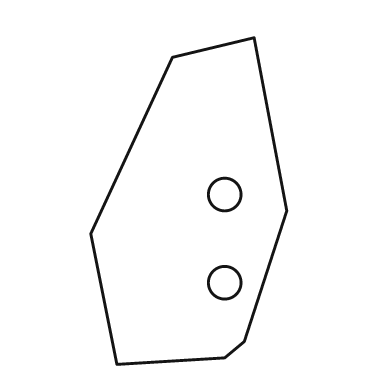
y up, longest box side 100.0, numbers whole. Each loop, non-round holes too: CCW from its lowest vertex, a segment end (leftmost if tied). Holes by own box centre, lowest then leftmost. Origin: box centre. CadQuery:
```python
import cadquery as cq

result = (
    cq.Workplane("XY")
    .moveTo(-22.0, -50.0)
    .lineTo(11.0, -48.0)
    .lineTo(17.0, -43.0)
    .lineTo(30.0, -3.0)
    .lineTo(20.0, 50.0)
    .lineTo(-5.0, 44.0)
    .lineTo(-30.0, -10.0)
    .close()
    .moveTo(11.0, -25.0)
    .circle(5.0)
    .moveTo(11.0, 2.0)
    .circle(5.0)
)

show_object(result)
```